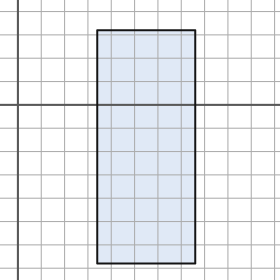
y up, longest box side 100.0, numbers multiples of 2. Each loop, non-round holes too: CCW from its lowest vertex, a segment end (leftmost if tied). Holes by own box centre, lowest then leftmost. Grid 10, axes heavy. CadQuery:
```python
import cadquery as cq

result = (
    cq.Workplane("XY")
    .moveTo(34.0, -68.0)
    .lineTo(76.0, -68.0)
    .lineTo(76.0, 32.0)
    .lineTo(34.0, 32.0)
    .close()
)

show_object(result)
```